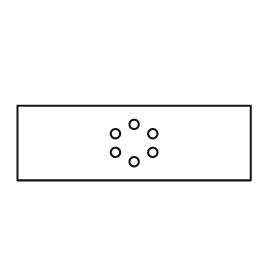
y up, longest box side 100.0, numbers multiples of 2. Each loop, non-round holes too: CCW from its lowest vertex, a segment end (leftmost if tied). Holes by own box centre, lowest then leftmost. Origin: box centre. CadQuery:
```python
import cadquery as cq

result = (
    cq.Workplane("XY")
    .moveTo(-50.0, -16.0)
    .lineTo(50.0, -16.0)
    .lineTo(50.0, 16.0)
    .lineTo(-50.0, 16.0)
    .close()
    .moveTo(0.0, -8.0)
    .circle(2.0)
    .moveTo(-8.0, -4.0)
    .circle(2.0)
    .moveTo(8.0, -4.0)
    .circle(2.0)
    .moveTo(-8.0, 4.0)
    .circle(2.0)
    .moveTo(8.0, 4.0)
    .circle(2.0)
    .moveTo(0.0, 8.0)
    .circle(2.0)
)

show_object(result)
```